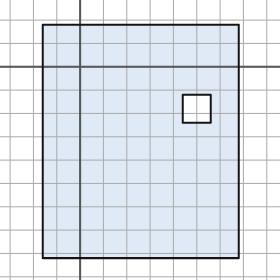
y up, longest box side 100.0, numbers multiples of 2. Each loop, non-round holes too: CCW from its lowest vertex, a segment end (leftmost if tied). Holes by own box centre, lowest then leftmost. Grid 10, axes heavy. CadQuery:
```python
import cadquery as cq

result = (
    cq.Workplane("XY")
    .moveTo(-16.0, -82.0)
    .lineTo(68.0, -82.0)
    .lineTo(68.0, 18.0)
    .lineTo(-16.0, 18.0)
    .close()
    .moveTo(44.0, -24.0)
    .lineTo(56.0, -24.0)
    .lineTo(56.0, -12.0)
    .lineTo(44.0, -12.0)
    .close()
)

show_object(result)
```